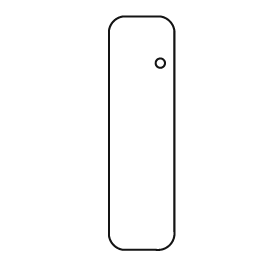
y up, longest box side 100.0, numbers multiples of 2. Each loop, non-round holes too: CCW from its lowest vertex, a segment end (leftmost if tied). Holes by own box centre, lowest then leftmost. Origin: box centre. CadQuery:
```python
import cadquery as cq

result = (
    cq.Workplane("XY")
    .moveTo(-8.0, -50.0)
    .lineTo(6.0, -50.0)
    .threePointArc((12.0, -48.0), (14.0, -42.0))
    .lineTo(14.0, 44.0)
    .threePointArc((12.0, 48.0), (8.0, 50.0))
    .lineTo(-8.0, 50.0)
    .threePointArc((-12.0, 48.0), (-14.0, 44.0))
    .lineTo(-14.0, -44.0)
    .threePointArc((-12.0, -48.0), (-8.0, -50.0))
    .close()
    .moveTo(8.0, 30.0)
    .circle(2.0)
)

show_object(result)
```